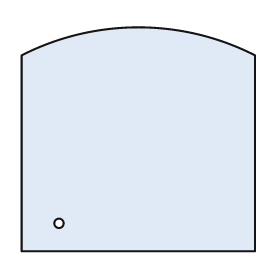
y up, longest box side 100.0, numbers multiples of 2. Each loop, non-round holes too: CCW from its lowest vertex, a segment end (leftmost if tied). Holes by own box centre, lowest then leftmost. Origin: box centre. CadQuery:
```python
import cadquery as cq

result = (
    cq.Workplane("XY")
    .moveTo(-50.0, -48.0)
    .lineTo(50.0, -48.0)
    .lineTo(50.0, 36.0)
    .threePointArc((0.0, 48.0), (-50.0, 36.0))
    .close()
    .moveTo(-34.0, -36.0)
    .circle(2.0)
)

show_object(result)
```